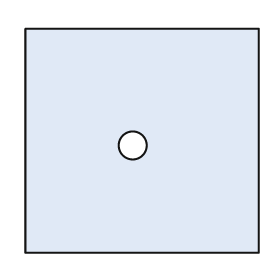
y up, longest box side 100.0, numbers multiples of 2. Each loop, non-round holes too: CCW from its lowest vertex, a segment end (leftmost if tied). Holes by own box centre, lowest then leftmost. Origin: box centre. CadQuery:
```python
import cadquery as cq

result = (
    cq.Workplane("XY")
    .moveTo(-50.0, -48.0)
    .lineTo(50.0, -48.0)
    .lineTo(50.0, 48.0)
    .lineTo(-50.0, 48.0)
    .close()
    .moveTo(-4.0, -2.0)
    .circle(6.0)
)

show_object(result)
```